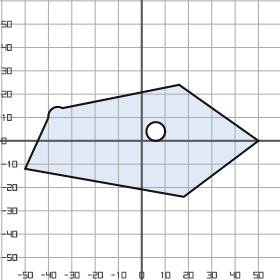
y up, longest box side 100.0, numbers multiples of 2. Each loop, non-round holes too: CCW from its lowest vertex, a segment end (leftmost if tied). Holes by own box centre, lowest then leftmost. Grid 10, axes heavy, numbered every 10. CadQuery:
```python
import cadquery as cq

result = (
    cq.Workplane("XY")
    .moveTo(18.0, -24.0)
    .lineTo(50.0, 0.0)
    .lineTo(16.0, 24.0)
    .lineTo(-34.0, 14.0)
    .threePointArc((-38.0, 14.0), (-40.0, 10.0))
    .lineTo(-50.0, -12.0)
    .close()
    .moveTo(6.0, 4.0)
    .circle(4.0)
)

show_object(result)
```